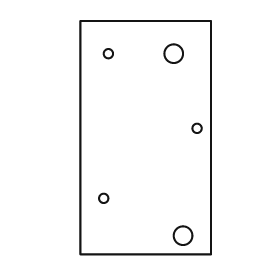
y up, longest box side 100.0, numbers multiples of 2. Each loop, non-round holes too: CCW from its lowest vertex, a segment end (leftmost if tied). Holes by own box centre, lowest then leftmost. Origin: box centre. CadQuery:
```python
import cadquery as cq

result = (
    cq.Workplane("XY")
    .moveTo(-28.0, -50.0)
    .lineTo(28.0, -50.0)
    .lineTo(28.0, 50.0)
    .lineTo(-28.0, 50.0)
    .close()
    .moveTo(16.0, -42.0)
    .circle(4.0)
    .moveTo(-18.0, -26.0)
    .circle(2.0)
    .moveTo(22.0, 4.0)
    .circle(2.0)
    .moveTo(-16.0, 36.0)
    .circle(2.0)
    .moveTo(12.0, 36.0)
    .circle(4.0)
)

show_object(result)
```